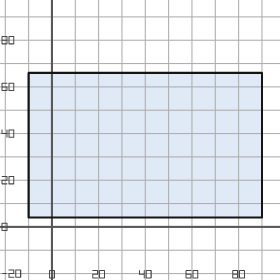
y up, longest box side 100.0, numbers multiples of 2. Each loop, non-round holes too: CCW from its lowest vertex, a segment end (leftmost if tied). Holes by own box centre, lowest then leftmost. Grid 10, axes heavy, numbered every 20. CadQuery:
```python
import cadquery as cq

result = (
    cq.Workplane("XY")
    .moveTo(-10.0, 4.0)
    .lineTo(90.0, 4.0)
    .lineTo(90.0, 66.0)
    .lineTo(-10.0, 66.0)
    .close()
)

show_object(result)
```